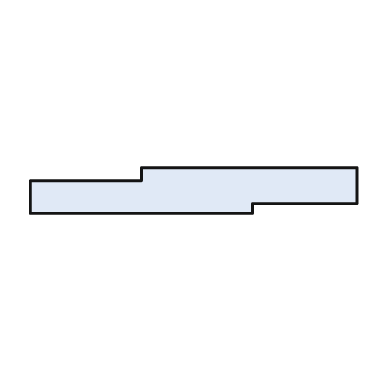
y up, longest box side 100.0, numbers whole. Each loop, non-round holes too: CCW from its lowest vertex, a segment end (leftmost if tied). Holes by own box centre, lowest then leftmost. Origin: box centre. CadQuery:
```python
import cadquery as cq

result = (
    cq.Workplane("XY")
    .moveTo(-50.0, -7.0)
    .lineTo(18.0, -7.0)
    .lineTo(18.0, -4.0)
    .lineTo(50.0, -4.0)
    .lineTo(50.0, 7.0)
    .lineTo(-16.0, 7.0)
    .lineTo(-16.0, 3.0)
    .lineTo(-50.0, 3.0)
    .close()
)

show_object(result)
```